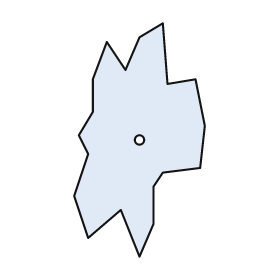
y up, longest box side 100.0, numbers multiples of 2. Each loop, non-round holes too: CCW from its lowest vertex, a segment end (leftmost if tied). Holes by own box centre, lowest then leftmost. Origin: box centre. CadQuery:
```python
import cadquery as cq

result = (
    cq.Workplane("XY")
    .moveTo(0.0, -50.0)
    .lineTo(6.0, -36.0)
    .lineTo(6.0, -20.0)
    .lineTo(10.0, -14.0)
    .lineTo(26.0, -12.0)
    .lineTo(28.0, 6.0)
    .lineTo(24.0, 26.0)
    .lineTo(12.0, 24.0)
    .lineTo(10.0, 50.0)
    .lineTo(0.0, 44.0)
    .lineTo(-6.0, 30.0)
    .lineTo(-14.0, 42.0)
    .lineTo(-20.0, 26.0)
    .lineTo(-20.0, 12.0)
    .lineTo(-26.0, 2.0)
    .lineTo(-22.0, -6.0)
    .lineTo(-28.0, -24.0)
    .lineTo(-22.0, -42.0)
    .lineTo(-8.0, -30.0)
    .close()
    .moveTo(0.0, 0.0)
    .circle(2.0)
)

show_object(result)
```